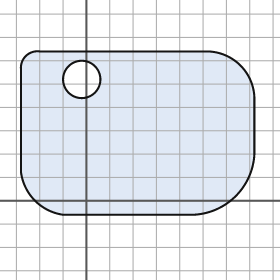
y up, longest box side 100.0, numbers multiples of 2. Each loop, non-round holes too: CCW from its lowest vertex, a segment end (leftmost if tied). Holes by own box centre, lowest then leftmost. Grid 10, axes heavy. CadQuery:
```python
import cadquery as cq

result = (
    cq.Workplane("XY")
    .moveTo(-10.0, -6.0)
    .lineTo(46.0, -6.0)
    .threePointArc((64.0, 2.0), (72.0, 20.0))
    .lineTo(72.0, 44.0)
    .threePointArc((66.0, 58.0), (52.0, 64.0))
    .lineTo(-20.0, 64.0)
    .threePointArc((-26.0, 62.0), (-28.0, 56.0))
    .lineTo(-28.0, 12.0)
    .threePointArc((-22.0, 0.0), (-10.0, -6.0))
    .close()
    .moveTo(-2.0, 52.0)
    .circle(8.0)
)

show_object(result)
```